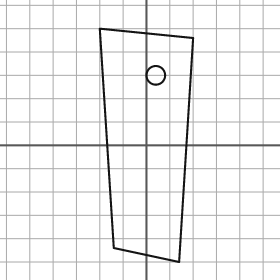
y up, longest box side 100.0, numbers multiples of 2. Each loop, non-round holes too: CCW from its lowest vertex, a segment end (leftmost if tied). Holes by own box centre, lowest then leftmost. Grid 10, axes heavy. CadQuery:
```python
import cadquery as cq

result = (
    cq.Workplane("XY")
    .moveTo(14.0, -50.0)
    .lineTo(20.0, 46.0)
    .lineTo(-20.0, 50.0)
    .lineTo(-14.0, -44.0)
    .close()
    .moveTo(4.0, 30.0)
    .circle(4.0)
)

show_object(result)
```